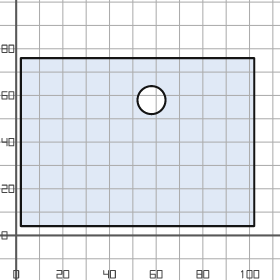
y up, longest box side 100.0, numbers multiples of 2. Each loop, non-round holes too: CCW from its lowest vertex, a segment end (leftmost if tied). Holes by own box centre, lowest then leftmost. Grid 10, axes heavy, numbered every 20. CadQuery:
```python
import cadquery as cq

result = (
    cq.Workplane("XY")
    .moveTo(2.0, 4.0)
    .lineTo(102.0, 4.0)
    .lineTo(102.0, 76.0)
    .lineTo(2.0, 76.0)
    .close()
    .moveTo(58.0, 58.0)
    .circle(6.0)
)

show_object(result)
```